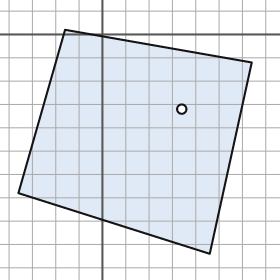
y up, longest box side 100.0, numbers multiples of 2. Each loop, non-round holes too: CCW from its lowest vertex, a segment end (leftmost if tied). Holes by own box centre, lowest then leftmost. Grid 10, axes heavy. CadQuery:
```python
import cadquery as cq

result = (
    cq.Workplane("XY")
    .moveTo(46.0, -94.0)
    .lineTo(64.0, -12.0)
    .lineTo(-16.0, 2.0)
    .lineTo(-36.0, -68.0)
    .close()
    .moveTo(34.0, -32.0)
    .circle(2.0)
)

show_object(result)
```